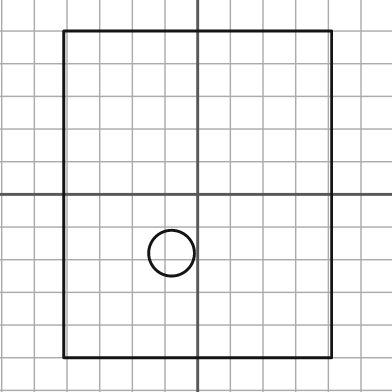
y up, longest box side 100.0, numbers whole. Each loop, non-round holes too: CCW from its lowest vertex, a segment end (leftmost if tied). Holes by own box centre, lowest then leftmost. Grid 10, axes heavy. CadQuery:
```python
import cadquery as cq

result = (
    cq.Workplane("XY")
    .moveTo(-41.0, -50.0)
    .lineTo(41.0, -50.0)
    .lineTo(41.0, 50.0)
    .lineTo(-41.0, 50.0)
    .close()
    .moveTo(-8.0, -18.0)
    .circle(7.0)
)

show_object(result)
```